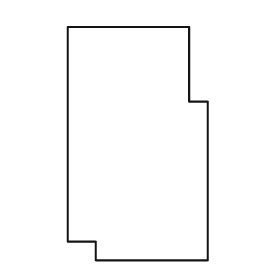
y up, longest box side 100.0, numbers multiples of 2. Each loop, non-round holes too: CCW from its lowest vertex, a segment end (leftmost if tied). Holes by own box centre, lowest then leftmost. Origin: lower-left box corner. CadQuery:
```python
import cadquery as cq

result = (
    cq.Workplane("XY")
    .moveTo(12.0, 0.0)
    .lineTo(60.0, 0.0)
    .lineTo(60.0, 68.0)
    .lineTo(52.0, 68.0)
    .lineTo(52.0, 100.0)
    .lineTo(0.0, 100.0)
    .lineTo(0.0, 8.0)
    .lineTo(12.0, 8.0)
    .close()
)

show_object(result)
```